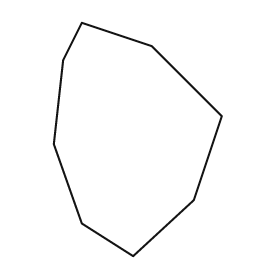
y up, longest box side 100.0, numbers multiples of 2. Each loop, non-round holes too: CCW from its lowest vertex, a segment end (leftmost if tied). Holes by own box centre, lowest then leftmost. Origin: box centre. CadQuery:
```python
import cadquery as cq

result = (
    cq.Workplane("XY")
    .moveTo(-2.0, -50.0)
    .lineTo(24.0, -26.0)
    .lineTo(36.0, 10.0)
    .lineTo(6.0, 40.0)
    .lineTo(-24.0, 50.0)
    .lineTo(-32.0, 34.0)
    .lineTo(-36.0, -2.0)
    .lineTo(-24.0, -36.0)
    .close()
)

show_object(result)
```